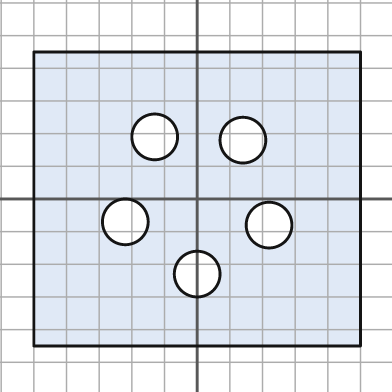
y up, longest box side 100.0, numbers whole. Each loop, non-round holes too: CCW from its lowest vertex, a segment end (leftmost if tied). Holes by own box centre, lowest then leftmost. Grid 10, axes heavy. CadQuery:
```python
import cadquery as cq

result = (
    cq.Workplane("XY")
    .moveTo(-50.0, -45.0)
    .lineTo(50.0, -45.0)
    .lineTo(50.0, 45.0)
    .lineTo(-50.0, 45.0)
    .close()
    .moveTo(0.0, -23.0)
    .circle(7.0)
    .moveTo(22.0, -8.0)
    .circle(7.0)
    .moveTo(-22.0, -7.0)
    .circle(7.0)
    .moveTo(14.0, 18.0)
    .circle(7.0)
    .moveTo(-13.0, 19.0)
    .circle(7.0)
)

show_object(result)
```